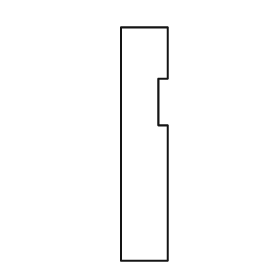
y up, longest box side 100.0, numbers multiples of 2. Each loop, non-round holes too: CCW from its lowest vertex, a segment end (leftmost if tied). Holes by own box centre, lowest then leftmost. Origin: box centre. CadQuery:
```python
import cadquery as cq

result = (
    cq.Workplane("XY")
    .moveTo(-10.0, -50.0)
    .lineTo(10.0, -50.0)
    .lineTo(10.0, 8.0)
    .lineTo(6.0, 8.0)
    .lineTo(6.0, 28.0)
    .lineTo(10.0, 28.0)
    .lineTo(10.0, 50.0)
    .lineTo(-10.0, 50.0)
    .close()
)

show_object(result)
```